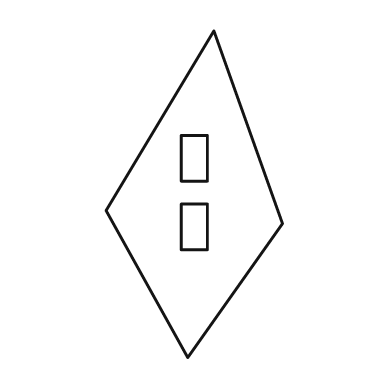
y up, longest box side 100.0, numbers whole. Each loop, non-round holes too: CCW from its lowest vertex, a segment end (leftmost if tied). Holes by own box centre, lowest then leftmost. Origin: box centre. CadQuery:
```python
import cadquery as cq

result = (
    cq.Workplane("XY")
    .moveTo(-2.0, -50.0)
    .lineTo(27.0, -9.0)
    .lineTo(6.0, 50.0)
    .lineTo(-27.0, -5.0)
    .close()
    .moveTo(-4.0, -17.0)
    .lineTo(4.0, -17.0)
    .lineTo(4.0, -3.0)
    .lineTo(-4.0, -3.0)
    .close()
    .moveTo(-4.0, 4.0)
    .lineTo(4.0, 4.0)
    .lineTo(4.0, 18.0)
    .lineTo(-4.0, 18.0)
    .close()
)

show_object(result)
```